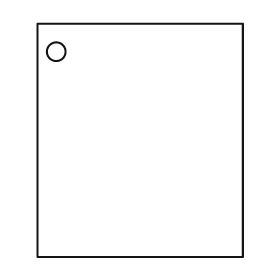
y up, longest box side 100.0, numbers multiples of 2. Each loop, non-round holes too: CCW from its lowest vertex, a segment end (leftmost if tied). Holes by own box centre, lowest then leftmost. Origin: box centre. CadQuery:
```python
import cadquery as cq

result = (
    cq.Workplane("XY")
    .moveTo(-44.0, -50.0)
    .lineTo(44.0, -50.0)
    .lineTo(44.0, 50.0)
    .lineTo(-44.0, 50.0)
    .close()
    .moveTo(-36.0, 38.0)
    .circle(4.0)
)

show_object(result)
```